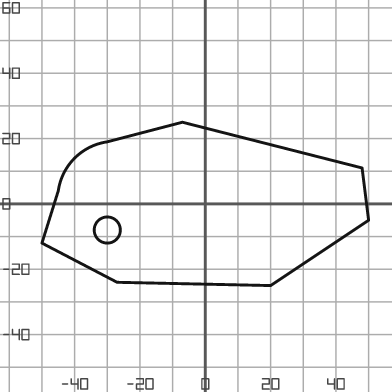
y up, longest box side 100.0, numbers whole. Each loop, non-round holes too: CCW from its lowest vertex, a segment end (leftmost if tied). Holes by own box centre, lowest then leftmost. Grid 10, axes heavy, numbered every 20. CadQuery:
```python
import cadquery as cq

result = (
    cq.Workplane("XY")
    .moveTo(20.0, -25.0)
    .lineTo(50.0, -5.0)
    .lineTo(48.0, 11.0)
    .lineTo(-7.0, 25.0)
    .lineTo(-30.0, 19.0)
    .threePointArc((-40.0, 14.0), (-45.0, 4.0))
    .lineTo(-50.0, -12.0)
    .lineTo(-27.0, -24.0)
    .close()
    .moveTo(-30.0, -8.0)
    .circle(4.0)
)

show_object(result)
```